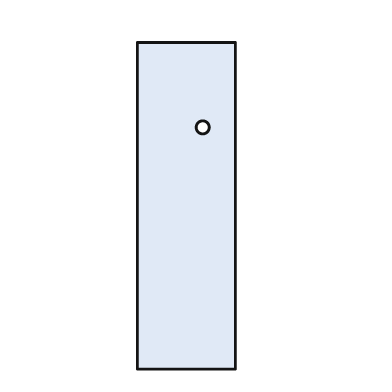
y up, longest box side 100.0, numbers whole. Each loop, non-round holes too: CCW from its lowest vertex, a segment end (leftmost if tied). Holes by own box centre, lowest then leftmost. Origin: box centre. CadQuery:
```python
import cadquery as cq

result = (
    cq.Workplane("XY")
    .moveTo(-15.0, -50.0)
    .lineTo(15.0, -50.0)
    .lineTo(15.0, 50.0)
    .lineTo(-15.0, 50.0)
    .close()
    .moveTo(5.0, 24.0)
    .circle(2.0)
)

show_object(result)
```